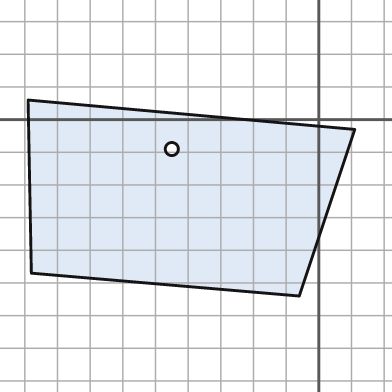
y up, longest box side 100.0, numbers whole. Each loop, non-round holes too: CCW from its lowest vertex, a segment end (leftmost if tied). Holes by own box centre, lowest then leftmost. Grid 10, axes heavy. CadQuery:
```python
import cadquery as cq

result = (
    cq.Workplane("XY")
    .moveTo(-6.0, -54.0)
    .lineTo(11.0, -3.0)
    .lineTo(-89.0, 6.0)
    .lineTo(-88.0, -47.0)
    .close()
    .moveTo(-45.0, -9.0)
    .circle(2.0)
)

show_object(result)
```